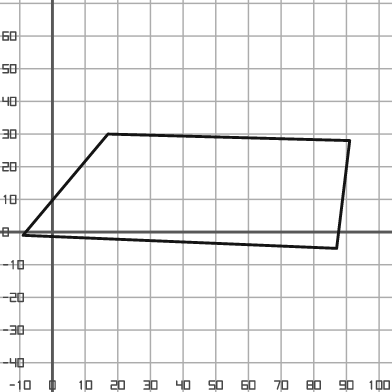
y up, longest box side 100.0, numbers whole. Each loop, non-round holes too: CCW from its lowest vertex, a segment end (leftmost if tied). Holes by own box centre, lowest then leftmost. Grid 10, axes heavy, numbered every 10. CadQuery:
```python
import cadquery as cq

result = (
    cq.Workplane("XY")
    .moveTo(87.0, -5.0)
    .lineTo(91.0, 28.0)
    .lineTo(17.0, 30.0)
    .lineTo(-9.0, -1.0)
    .close()
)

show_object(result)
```